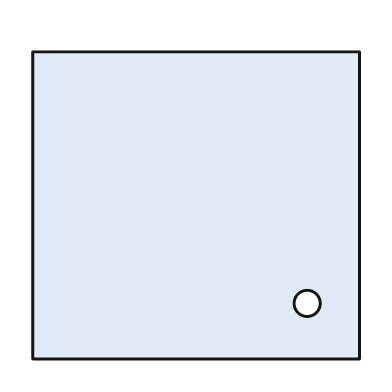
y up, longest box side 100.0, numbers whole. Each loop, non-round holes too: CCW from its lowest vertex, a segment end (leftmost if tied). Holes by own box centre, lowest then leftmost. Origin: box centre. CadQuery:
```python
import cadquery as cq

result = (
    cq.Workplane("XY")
    .moveTo(-50.0, -47.0)
    .lineTo(50.0, -47.0)
    .lineTo(50.0, 47.0)
    .lineTo(-50.0, 47.0)
    .close()
    .moveTo(34.0, -30.0)
    .circle(4.0)
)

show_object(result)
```